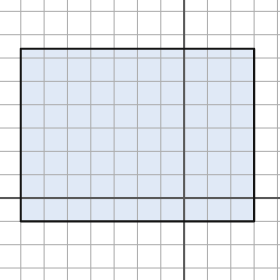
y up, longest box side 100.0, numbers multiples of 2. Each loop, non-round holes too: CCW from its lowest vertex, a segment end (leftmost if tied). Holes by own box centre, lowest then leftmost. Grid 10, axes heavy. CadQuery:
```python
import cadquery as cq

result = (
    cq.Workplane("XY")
    .moveTo(-70.0, -10.0)
    .lineTo(30.0, -10.0)
    .lineTo(30.0, 64.0)
    .lineTo(-70.0, 64.0)
    .close()
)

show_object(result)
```